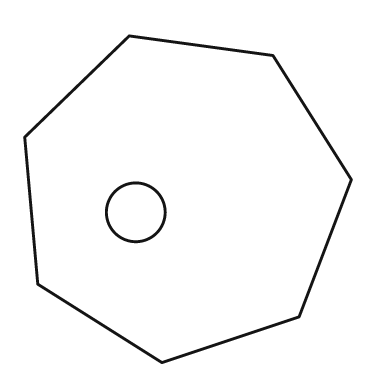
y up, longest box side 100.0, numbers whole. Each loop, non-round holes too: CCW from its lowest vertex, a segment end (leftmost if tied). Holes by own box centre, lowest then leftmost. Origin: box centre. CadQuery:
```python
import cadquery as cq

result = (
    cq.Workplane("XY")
    .moveTo(-8.0, -50.0)
    .lineTo(34.0, -36.0)
    .lineTo(50.0, 6.0)
    .lineTo(26.0, 44.0)
    .lineTo(-18.0, 50.0)
    .lineTo(-50.0, 19.0)
    .lineTo(-46.0, -26.0)
    .close()
    .moveTo(-16.0, -4.0)
    .circle(9.0)
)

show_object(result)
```